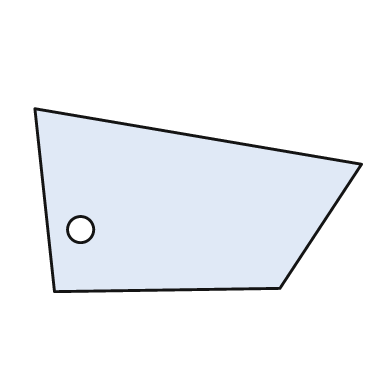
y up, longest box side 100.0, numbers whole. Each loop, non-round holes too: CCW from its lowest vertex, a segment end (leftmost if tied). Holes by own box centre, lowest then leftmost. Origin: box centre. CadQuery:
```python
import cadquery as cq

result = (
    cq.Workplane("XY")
    .moveTo(-44.0, -28.0)
    .lineTo(25.0, -27.0)
    .lineTo(50.0, 11.0)
    .lineTo(-50.0, 28.0)
    .close()
    .moveTo(-36.0, -9.0)
    .circle(4.0)
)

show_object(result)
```